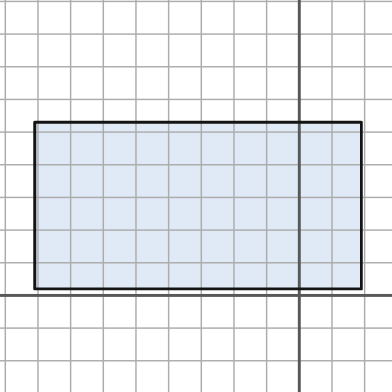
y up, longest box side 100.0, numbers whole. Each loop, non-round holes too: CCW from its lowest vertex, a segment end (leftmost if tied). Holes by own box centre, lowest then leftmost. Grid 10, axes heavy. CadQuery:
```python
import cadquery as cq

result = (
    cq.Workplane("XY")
    .moveTo(-81.0, 2.0)
    .lineTo(19.0, 2.0)
    .lineTo(19.0, 53.0)
    .lineTo(-81.0, 53.0)
    .close()
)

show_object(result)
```